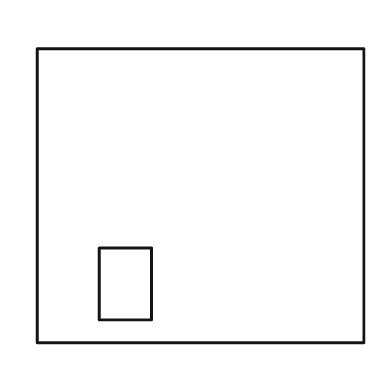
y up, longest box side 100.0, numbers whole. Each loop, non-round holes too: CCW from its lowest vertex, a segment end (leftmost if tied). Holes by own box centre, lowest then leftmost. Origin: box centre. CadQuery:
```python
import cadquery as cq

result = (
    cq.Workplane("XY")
    .moveTo(-50.0, -45.0)
    .lineTo(50.0, -45.0)
    .lineTo(50.0, 45.0)
    .lineTo(-50.0, 45.0)
    .close()
    .moveTo(-31.0, -38.0)
    .lineTo(-15.0, -38.0)
    .lineTo(-15.0, -16.0)
    .lineTo(-31.0, -16.0)
    .close()
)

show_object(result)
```